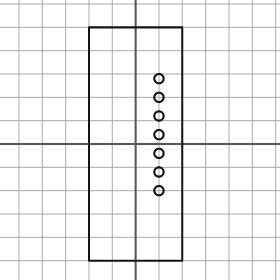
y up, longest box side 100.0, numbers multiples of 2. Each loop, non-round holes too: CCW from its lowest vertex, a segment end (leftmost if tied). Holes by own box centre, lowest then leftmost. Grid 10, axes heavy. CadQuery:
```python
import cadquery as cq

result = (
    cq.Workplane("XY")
    .moveTo(-20.0, -50.0)
    .lineTo(20.0, -50.0)
    .lineTo(20.0, 50.0)
    .lineTo(-20.0, 50.0)
    .close()
    .moveTo(10.0, -20.0)
    .circle(2.0)
    .moveTo(10.0, -12.0)
    .circle(2.0)
    .moveTo(10.0, -4.0)
    .circle(2.0)
    .moveTo(10.0, 4.0)
    .circle(2.0)
    .moveTo(10.0, 12.0)
    .circle(2.0)
    .moveTo(10.0, 20.0)
    .circle(2.0)
    .moveTo(10.0, 28.0)
    .circle(2.0)
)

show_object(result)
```